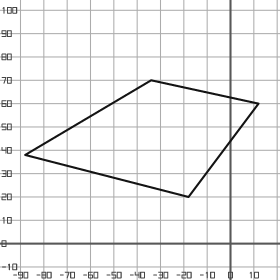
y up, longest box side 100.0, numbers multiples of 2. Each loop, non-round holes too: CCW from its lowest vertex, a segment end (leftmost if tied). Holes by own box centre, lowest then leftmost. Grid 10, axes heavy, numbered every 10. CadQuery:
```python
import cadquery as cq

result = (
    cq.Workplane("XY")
    .moveTo(-18.0, 20.0)
    .lineTo(12.0, 60.0)
    .lineTo(-34.0, 70.0)
    .lineTo(-88.0, 38.0)
    .close()
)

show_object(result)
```